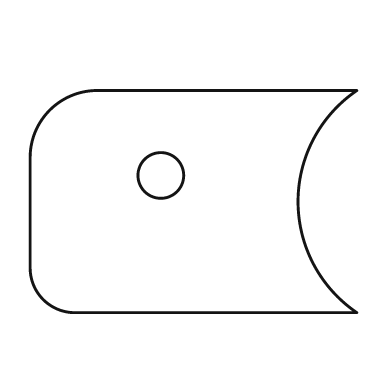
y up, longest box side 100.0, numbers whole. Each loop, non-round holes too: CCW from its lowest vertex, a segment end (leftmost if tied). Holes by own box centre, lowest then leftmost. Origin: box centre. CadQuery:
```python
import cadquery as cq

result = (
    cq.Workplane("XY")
    .moveTo(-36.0, -34.0)
    .lineTo(50.0, -34.0)
    .threePointArc((32.0, 0.0), (50.0, 34.0))
    .lineTo(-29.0, 34.0)
    .threePointArc((-44.0, 28.0), (-50.0, 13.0))
    .lineTo(-50.0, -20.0)
    .threePointArc((-46.0, -30.0), (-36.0, -34.0))
    .close()
    .moveTo(-10.0, 8.0)
    .circle(7.0)
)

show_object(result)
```